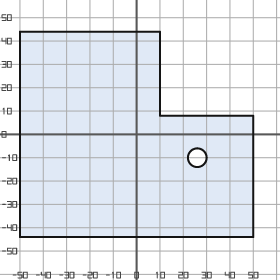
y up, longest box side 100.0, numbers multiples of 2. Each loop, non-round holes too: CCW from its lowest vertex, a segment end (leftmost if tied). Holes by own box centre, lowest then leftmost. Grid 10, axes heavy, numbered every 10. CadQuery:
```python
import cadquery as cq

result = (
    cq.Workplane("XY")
    .moveTo(-50.0, -44.0)
    .lineTo(50.0, -44.0)
    .lineTo(50.0, 8.0)
    .lineTo(10.0, 8.0)
    .lineTo(10.0, 44.0)
    .lineTo(-50.0, 44.0)
    .close()
    .moveTo(26.0, -10.0)
    .circle(4.0)
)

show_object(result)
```